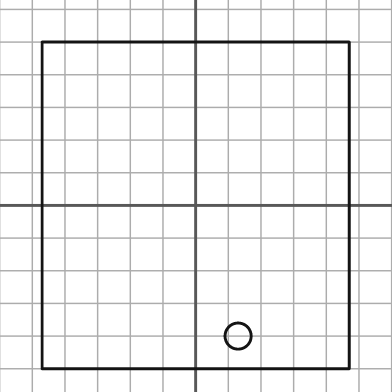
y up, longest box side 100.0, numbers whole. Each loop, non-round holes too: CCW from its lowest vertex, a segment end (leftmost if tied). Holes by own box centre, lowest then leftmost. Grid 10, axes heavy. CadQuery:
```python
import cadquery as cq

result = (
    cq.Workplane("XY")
    .moveTo(-47.0, -50.0)
    .lineTo(47.0, -50.0)
    .lineTo(47.0, 50.0)
    .lineTo(-47.0, 50.0)
    .close()
    .moveTo(13.0, -40.0)
    .circle(4.0)
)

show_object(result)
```